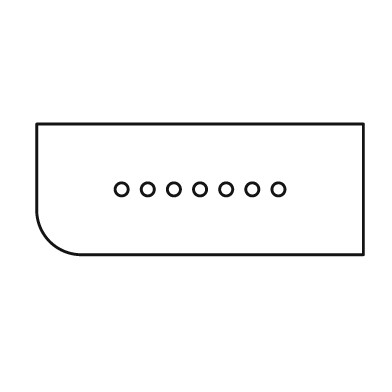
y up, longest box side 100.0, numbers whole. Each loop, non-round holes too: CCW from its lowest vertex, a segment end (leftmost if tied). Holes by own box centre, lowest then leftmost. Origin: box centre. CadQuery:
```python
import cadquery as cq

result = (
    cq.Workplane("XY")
    .moveTo(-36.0, -20.0)
    .lineTo(50.0, -20.0)
    .lineTo(50.0, 20.0)
    .lineTo(-50.0, 20.0)
    .lineTo(-50.0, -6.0)
    .threePointArc((-46.0, -16.0), (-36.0, -20.0))
    .close()
    .moveTo(-24.0, 0.0)
    .circle(2.0)
    .moveTo(-16.0, 0.0)
    .circle(2.0)
    .moveTo(-8.0, 0.0)
    .circle(2.0)
    .moveTo(0.0, 0.0)
    .circle(2.0)
    .moveTo(8.0, 0.0)
    .circle(2.0)
    .moveTo(16.0, 0.0)
    .circle(2.0)
    .moveTo(24.0, 0.0)
    .circle(2.0)
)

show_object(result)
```